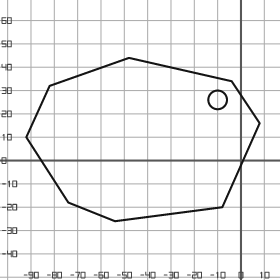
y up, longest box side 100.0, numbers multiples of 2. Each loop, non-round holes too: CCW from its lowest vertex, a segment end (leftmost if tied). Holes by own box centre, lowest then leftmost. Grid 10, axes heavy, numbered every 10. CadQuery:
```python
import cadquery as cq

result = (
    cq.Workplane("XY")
    .moveTo(-54.0, -26.0)
    .lineTo(-8.0, -20.0)
    .lineTo(8.0, 16.0)
    .lineTo(-4.0, 34.0)
    .lineTo(-48.0, 44.0)
    .lineTo(-82.0, 32.0)
    .lineTo(-92.0, 10.0)
    .lineTo(-74.0, -18.0)
    .close()
    .moveTo(-10.0, 26.0)
    .circle(4.0)
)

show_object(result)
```